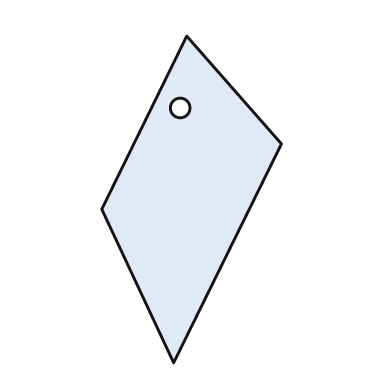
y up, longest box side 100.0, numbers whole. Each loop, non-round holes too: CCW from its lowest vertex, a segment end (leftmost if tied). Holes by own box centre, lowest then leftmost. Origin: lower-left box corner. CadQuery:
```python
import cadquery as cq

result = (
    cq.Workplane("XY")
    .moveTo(22.0, 0.0)
    .lineTo(55.0, 67.0)
    .lineTo(26.0, 100.0)
    .lineTo(0.0, 47.0)
    .close()
    .moveTo(24.0, 78.0)
    .circle(3.0)
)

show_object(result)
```